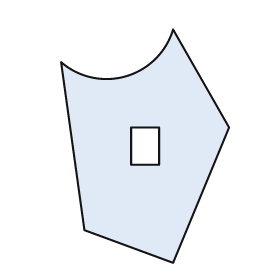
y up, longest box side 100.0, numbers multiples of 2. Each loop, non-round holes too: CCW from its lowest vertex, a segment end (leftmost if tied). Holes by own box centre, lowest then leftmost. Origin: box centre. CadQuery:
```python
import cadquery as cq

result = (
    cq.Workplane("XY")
    .moveTo(12.0, -50.0)
    .lineTo(36.0, 8.0)
    .lineTo(12.0, 50.0)
    .threePointArc((-8.0, 30.0), (-36.0, 36.0))
    .lineTo(-26.0, -36.0)
    .close()
    .moveTo(-6.0, -8.0)
    .lineTo(6.0, -8.0)
    .lineTo(6.0, 8.0)
    .lineTo(-6.0, 8.0)
    .close()
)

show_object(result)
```